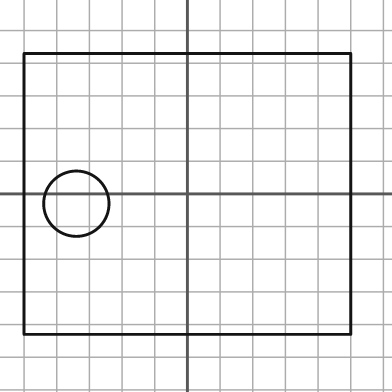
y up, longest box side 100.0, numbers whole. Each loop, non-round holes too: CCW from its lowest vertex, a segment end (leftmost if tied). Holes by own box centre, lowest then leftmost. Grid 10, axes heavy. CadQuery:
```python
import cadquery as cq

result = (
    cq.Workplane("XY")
    .moveTo(-50.0, -43.0)
    .lineTo(50.0, -43.0)
    .lineTo(50.0, 43.0)
    .lineTo(-50.0, 43.0)
    .close()
    .moveTo(-34.0, -3.0)
    .circle(10.0)
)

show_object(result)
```